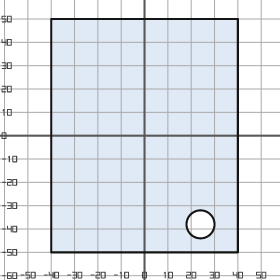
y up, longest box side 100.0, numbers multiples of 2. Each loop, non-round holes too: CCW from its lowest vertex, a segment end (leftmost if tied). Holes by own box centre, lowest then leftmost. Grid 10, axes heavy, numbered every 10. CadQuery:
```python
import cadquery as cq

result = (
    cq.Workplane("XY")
    .moveTo(-40.0, -50.0)
    .lineTo(40.0, -50.0)
    .lineTo(40.0, 50.0)
    .lineTo(-40.0, 50.0)
    .close()
    .moveTo(24.0, -38.0)
    .circle(6.0)
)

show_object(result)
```